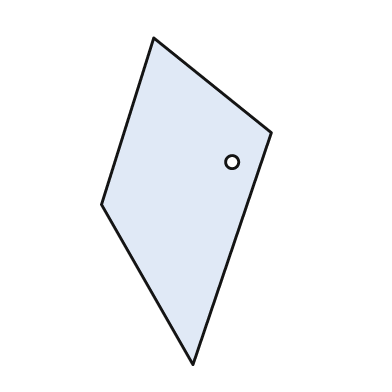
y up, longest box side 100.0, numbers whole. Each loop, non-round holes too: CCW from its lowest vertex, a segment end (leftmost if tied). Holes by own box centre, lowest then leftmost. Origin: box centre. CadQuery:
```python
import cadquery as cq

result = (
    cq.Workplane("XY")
    .moveTo(2.0, -50.0)
    .lineTo(26.0, 21.0)
    .lineTo(-10.0, 50.0)
    .lineTo(-26.0, -1.0)
    .close()
    .moveTo(14.0, 12.0)
    .circle(2.0)
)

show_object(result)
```